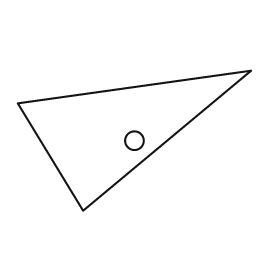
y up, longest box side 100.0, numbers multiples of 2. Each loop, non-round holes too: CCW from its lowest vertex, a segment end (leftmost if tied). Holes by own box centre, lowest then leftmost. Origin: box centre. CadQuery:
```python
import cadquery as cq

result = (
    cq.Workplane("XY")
    .moveTo(-22.0, -30.0)
    .lineTo(50.0, 30.0)
    .lineTo(-50.0, 16.0)
    .close()
    .moveTo(0.0, 0.0)
    .circle(4.0)
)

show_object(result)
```